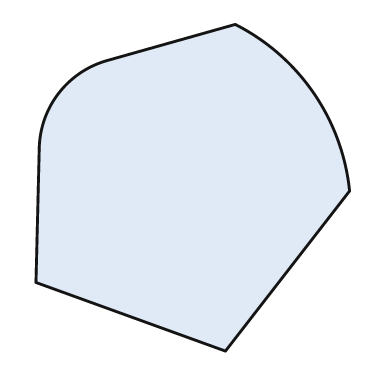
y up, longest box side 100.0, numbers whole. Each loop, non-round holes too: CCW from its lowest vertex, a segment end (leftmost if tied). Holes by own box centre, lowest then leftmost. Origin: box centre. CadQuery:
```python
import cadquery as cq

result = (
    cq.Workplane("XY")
    .moveTo(10.0, -50.0)
    .lineTo(48.0, -1.0)
    .threePointArc((37.0, 29.0), (13.0, 50.0))
    .lineTo(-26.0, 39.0)
    .threePointArc((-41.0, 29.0), (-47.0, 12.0))
    .lineTo(-48.0, -29.0)
    .close()
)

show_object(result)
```